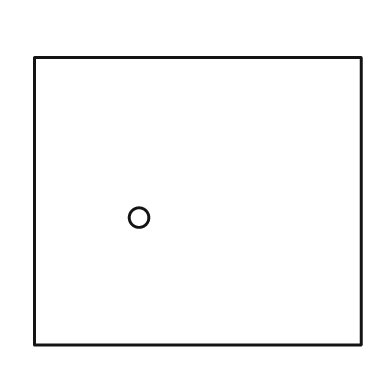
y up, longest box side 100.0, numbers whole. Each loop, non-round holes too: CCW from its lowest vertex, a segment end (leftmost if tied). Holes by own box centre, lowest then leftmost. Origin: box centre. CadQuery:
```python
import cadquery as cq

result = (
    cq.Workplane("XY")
    .moveTo(-50.0, -44.0)
    .lineTo(50.0, -44.0)
    .lineTo(50.0, 44.0)
    .lineTo(-50.0, 44.0)
    .close()
    .moveTo(-18.0, -5.0)
    .circle(3.0)
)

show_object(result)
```